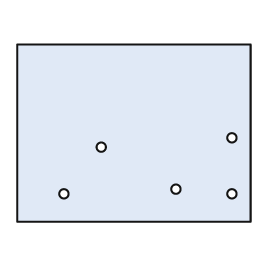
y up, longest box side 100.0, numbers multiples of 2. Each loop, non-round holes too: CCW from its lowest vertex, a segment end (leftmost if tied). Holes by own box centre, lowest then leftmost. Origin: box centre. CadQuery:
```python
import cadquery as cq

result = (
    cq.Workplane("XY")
    .moveTo(-50.0, -38.0)
    .lineTo(50.0, -38.0)
    .lineTo(50.0, 38.0)
    .lineTo(-50.0, 38.0)
    .close()
    .moveTo(-30.0, -26.0)
    .circle(2.0)
    .moveTo(42.0, -26.0)
    .circle(2.0)
    .moveTo(18.0, -24.0)
    .circle(2.0)
    .moveTo(-14.0, -6.0)
    .circle(2.0)
    .moveTo(42.0, -2.0)
    .circle(2.0)
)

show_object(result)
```